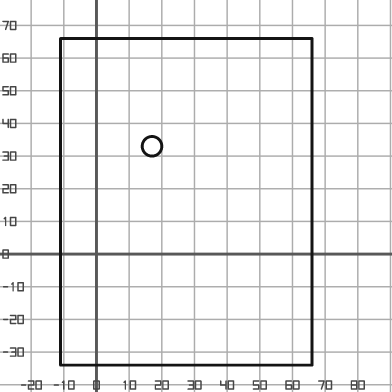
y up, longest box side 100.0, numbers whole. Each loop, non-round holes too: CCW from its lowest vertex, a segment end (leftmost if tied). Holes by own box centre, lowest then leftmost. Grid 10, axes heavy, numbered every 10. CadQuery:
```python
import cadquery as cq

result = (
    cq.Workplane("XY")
    .moveTo(-11.0, -34.0)
    .lineTo(66.0, -34.0)
    .lineTo(66.0, 66.0)
    .lineTo(-11.0, 66.0)
    .close()
    .moveTo(17.0, 33.0)
    .circle(3.0)
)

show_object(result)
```